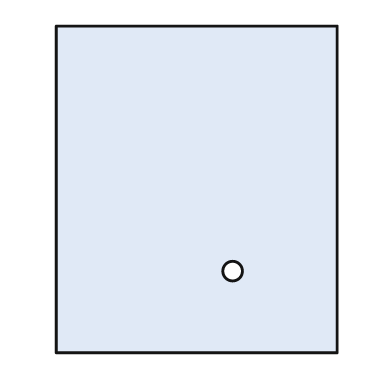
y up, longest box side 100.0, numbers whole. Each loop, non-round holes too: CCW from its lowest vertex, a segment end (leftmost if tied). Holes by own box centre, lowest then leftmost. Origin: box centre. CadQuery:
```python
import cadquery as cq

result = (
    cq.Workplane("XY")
    .moveTo(-43.0, -50.0)
    .lineTo(43.0, -50.0)
    .lineTo(43.0, 50.0)
    .lineTo(-43.0, 50.0)
    .close()
    .moveTo(11.0, -25.0)
    .circle(3.0)
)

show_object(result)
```